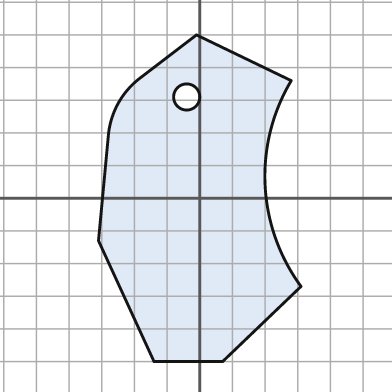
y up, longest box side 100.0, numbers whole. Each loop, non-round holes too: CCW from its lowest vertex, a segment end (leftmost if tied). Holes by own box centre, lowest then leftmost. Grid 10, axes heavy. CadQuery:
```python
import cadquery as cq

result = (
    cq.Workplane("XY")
    .moveTo(-14.0, -50.0)
    .lineTo(7.0, -50.0)
    .lineTo(31.0, -27.0)
    .threePointArc((20.0, 4.0), (28.0, 36.0))
    .lineTo(-1.0, 50.0)
    .lineTo(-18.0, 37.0)
    .threePointArc((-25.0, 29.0), (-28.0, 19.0))
    .lineTo(-31.0, -13.0)
    .close()
    .moveTo(-4.0, 31.0)
    .circle(4.0)
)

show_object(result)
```